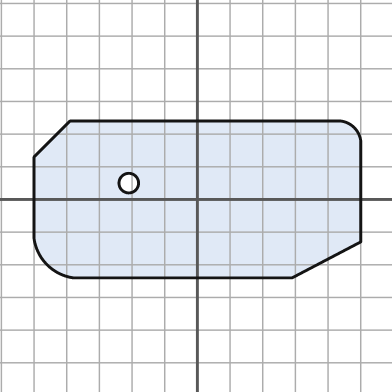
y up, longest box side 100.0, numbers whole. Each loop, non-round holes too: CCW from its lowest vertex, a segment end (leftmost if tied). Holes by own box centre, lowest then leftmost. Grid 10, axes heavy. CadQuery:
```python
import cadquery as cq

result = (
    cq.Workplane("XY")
    .moveTo(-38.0, -24.0)
    .lineTo(29.0, -24.0)
    .lineTo(50.0, -13.0)
    .lineTo(50.0, 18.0)
    .threePointArc((48.0, 22.0), (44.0, 24.0))
    .lineTo(-39.0, 24.0)
    .lineTo(-50.0, 13.0)
    .lineTo(-50.0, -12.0)
    .threePointArc((-46.0, -20.0), (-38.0, -24.0))
    .close()
    .moveTo(-21.0, 5.0)
    .circle(3.0)
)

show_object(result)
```